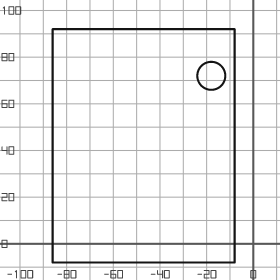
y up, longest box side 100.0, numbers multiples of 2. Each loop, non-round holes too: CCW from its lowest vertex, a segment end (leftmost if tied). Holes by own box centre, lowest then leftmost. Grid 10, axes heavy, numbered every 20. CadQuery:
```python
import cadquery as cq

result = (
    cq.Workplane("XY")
    .moveTo(-86.0, -8.0)
    .lineTo(-8.0, -8.0)
    .lineTo(-8.0, 92.0)
    .lineTo(-86.0, 92.0)
    .close()
    .moveTo(-18.0, 72.0)
    .circle(6.0)
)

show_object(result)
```